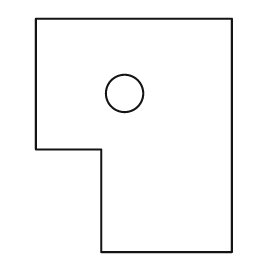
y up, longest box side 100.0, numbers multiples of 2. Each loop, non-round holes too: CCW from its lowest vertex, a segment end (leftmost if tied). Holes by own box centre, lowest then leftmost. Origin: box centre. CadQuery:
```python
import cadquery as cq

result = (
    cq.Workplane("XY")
    .moveTo(-14.0, -50.0)
    .lineTo(42.0, -50.0)
    .lineTo(42.0, 50.0)
    .lineTo(-42.0, 50.0)
    .lineTo(-42.0, -6.0)
    .lineTo(-14.0, -6.0)
    .close()
    .moveTo(-4.0, 18.0)
    .circle(8.0)
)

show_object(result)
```